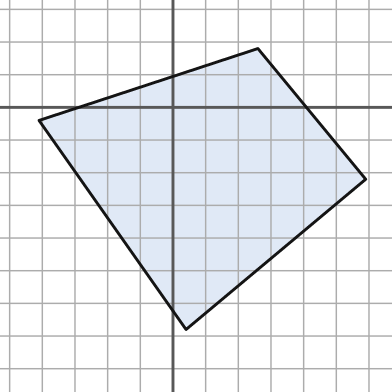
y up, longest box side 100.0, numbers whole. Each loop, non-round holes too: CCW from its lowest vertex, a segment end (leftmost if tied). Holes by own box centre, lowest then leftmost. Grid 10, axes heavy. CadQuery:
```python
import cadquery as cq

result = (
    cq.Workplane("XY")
    .moveTo(4.0, -68.0)
    .lineTo(59.0, -22.0)
    .lineTo(26.0, 18.0)
    .lineTo(-41.0, -4.0)
    .close()
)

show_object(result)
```